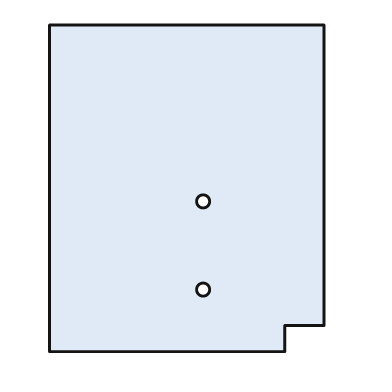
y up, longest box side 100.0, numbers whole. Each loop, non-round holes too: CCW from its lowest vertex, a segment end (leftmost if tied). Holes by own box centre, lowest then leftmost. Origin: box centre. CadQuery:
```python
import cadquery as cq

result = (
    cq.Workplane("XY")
    .moveTo(-42.0, -50.0)
    .lineTo(30.0, -50.0)
    .lineTo(30.0, -42.0)
    .lineTo(42.0, -42.0)
    .lineTo(42.0, 50.0)
    .lineTo(-42.0, 50.0)
    .close()
    .moveTo(5.0, -31.0)
    .circle(2.0)
    .moveTo(5.0, -4.0)
    .circle(2.0)
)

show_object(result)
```